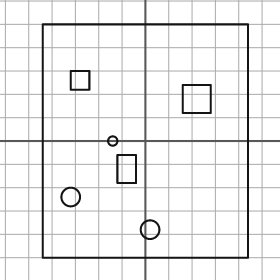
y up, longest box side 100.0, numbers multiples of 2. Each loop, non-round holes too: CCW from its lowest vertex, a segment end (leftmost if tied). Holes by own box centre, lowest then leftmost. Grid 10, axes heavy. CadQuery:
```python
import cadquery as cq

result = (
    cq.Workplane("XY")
    .moveTo(-44.0, -50.0)
    .lineTo(44.0, -50.0)
    .lineTo(44.0, 50.0)
    .lineTo(-44.0, 50.0)
    .close()
    .moveTo(2.0, -38.0)
    .circle(4.0)
    .moveTo(-32.0, -24.0)
    .circle(4.0)
    .moveTo(-12.0, -18.0)
    .lineTo(-4.0, -18.0)
    .lineTo(-4.0, -6.0)
    .lineTo(-12.0, -6.0)
    .close()
    .moveTo(-14.0, 0.0)
    .circle(2.0)
    .moveTo(16.0, 12.0)
    .lineTo(28.0, 12.0)
    .lineTo(28.0, 24.0)
    .lineTo(16.0, 24.0)
    .close()
    .moveTo(-32.0, 22.0)
    .lineTo(-24.0, 22.0)
    .lineTo(-24.0, 30.0)
    .lineTo(-32.0, 30.0)
    .close()
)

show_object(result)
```